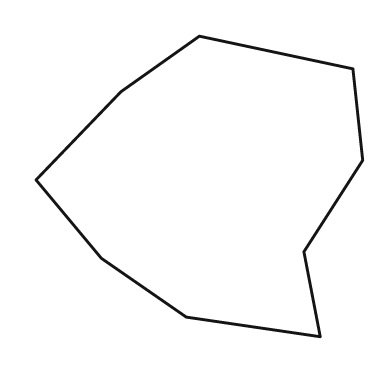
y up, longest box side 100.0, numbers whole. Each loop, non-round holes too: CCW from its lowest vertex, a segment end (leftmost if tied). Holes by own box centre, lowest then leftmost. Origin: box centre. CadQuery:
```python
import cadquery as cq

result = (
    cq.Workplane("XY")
    .moveTo(37.0, -46.0)
    .lineTo(32.0, -20.0)
    .lineTo(50.0, 8.0)
    .lineTo(47.0, 36.0)
    .lineTo(0.0, 46.0)
    .lineTo(-24.0, 29.0)
    .lineTo(-50.0, 2.0)
    .lineTo(-30.0, -22.0)
    .lineTo(-4.0, -40.0)
    .close()
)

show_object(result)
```